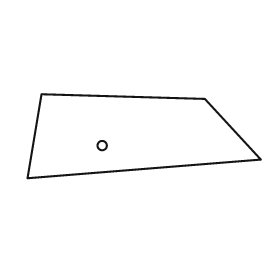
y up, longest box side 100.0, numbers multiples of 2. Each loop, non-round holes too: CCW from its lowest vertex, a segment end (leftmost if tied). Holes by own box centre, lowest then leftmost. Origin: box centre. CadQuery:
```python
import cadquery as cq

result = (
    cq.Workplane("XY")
    .moveTo(-50.0, -18.0)
    .lineTo(50.0, -10.0)
    .lineTo(26.0, 16.0)
    .lineTo(-44.0, 18.0)
    .close()
    .moveTo(-18.0, -4.0)
    .circle(2.0)
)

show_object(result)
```